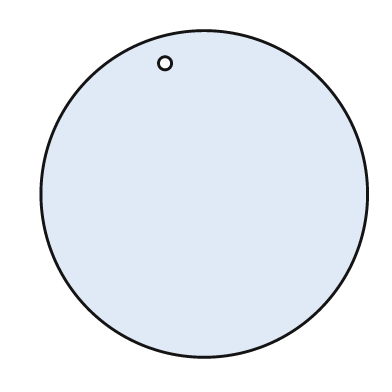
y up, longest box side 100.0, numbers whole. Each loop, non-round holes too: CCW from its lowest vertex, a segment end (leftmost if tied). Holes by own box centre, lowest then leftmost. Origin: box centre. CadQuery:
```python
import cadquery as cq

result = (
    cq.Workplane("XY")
    .moveTo(0.0, 0.0)
    .circle(50.0)
    .moveTo(-12.0, 40.0)
    .circle(2.0)
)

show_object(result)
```